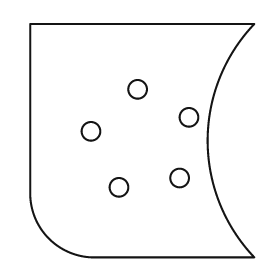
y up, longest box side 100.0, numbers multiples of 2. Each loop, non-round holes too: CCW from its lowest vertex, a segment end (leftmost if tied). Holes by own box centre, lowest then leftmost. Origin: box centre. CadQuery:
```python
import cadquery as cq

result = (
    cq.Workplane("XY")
    .moveTo(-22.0, -50.0)
    .lineTo(48.0, -50.0)
    .threePointArc((28.0, 0.0), (48.0, 50.0))
    .lineTo(-48.0, 50.0)
    .lineTo(-48.0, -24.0)
    .threePointArc((-40.0, -42.0), (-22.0, -50.0))
    .close()
    .moveTo(-10.0, -20.0)
    .circle(4.0)
    .moveTo(16.0, -16.0)
    .circle(4.0)
    .moveTo(-22.0, 4.0)
    .circle(4.0)
    .moveTo(20.0, 10.0)
    .circle(4.0)
    .moveTo(-2.0, 22.0)
    .circle(4.0)
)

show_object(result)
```